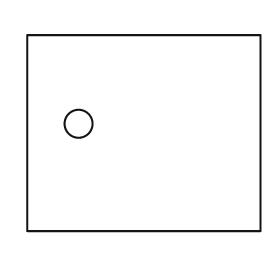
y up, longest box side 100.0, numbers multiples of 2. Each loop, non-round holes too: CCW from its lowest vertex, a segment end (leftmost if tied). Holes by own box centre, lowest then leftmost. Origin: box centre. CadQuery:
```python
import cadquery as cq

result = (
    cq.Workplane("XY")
    .moveTo(-50.0, -42.0)
    .lineTo(50.0, -42.0)
    .lineTo(50.0, 42.0)
    .lineTo(-50.0, 42.0)
    .close()
    .moveTo(-28.0, 4.0)
    .circle(6.0)
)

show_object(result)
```